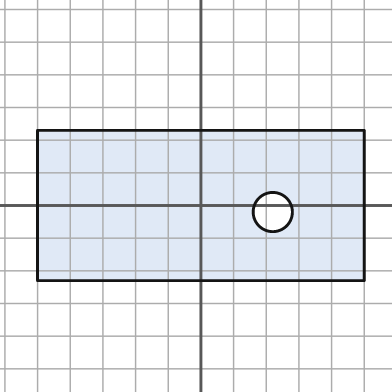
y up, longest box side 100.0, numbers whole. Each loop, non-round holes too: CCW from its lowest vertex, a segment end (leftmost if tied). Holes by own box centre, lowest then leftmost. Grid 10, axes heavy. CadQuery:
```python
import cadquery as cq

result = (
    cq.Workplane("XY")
    .moveTo(-50.0, -23.0)
    .lineTo(50.0, -23.0)
    .lineTo(50.0, 23.0)
    .lineTo(-50.0, 23.0)
    .close()
    .moveTo(22.0, -2.0)
    .circle(6.0)
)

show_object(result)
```